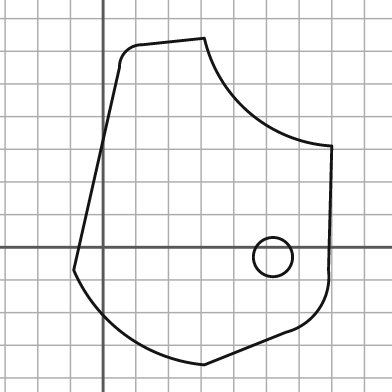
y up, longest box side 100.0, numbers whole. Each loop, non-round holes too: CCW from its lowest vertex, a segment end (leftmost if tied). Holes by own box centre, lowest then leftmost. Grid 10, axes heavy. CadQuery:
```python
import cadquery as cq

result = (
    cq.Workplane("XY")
    .moveTo(31.0, -36.0)
    .lineTo(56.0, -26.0)
    .threePointArc((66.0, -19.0), (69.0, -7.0))
    .lineTo(70.0, 31.0)
    .threePointArc((45.0, 41.0), (31.0, 64.0))
    .lineTo(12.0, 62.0)
    .threePointArc((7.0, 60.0), (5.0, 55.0))
    .lineTo(-9.0, -7.0)
    .threePointArc((7.0, -27.0), (31.0, -36.0))
    .close()
    .moveTo(52.0, -3.0)
    .circle(6.0)
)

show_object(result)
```